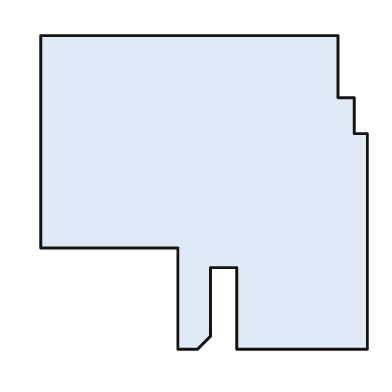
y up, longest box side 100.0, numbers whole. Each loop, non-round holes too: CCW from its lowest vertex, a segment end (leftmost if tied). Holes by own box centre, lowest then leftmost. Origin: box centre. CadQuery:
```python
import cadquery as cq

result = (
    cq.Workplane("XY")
    .moveTo(-8.0, -48.0)
    .lineTo(-2.0, -48.0)
    .lineTo(2.0, -44.0)
    .lineTo(2.0, -23.0)
    .lineTo(10.0, -23.0)
    .lineTo(10.0, -48.0)
    .lineTo(50.0, -48.0)
    .lineTo(50.0, 18.0)
    .lineTo(46.0, 18.0)
    .lineTo(46.0, 29.0)
    .lineTo(41.0, 29.0)
    .lineTo(41.0, 48.0)
    .lineTo(-50.0, 48.0)
    .lineTo(-50.0, -17.0)
    .lineTo(-8.0, -17.0)
    .close()
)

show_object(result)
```